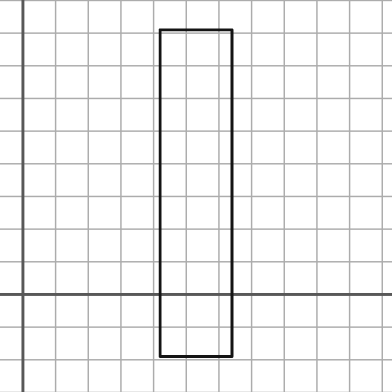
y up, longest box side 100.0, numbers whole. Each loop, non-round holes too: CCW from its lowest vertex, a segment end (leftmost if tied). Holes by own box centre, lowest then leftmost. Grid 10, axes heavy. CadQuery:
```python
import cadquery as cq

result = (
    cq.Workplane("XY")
    .moveTo(42.0, -19.0)
    .lineTo(64.0, -19.0)
    .lineTo(64.0, 81.0)
    .lineTo(42.0, 81.0)
    .close()
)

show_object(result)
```